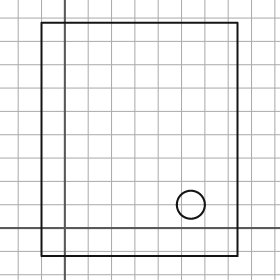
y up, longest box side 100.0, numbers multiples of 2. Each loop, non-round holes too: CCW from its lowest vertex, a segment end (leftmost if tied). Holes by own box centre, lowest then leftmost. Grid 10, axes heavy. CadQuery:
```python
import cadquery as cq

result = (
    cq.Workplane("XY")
    .moveTo(-10.0, -12.0)
    .lineTo(74.0, -12.0)
    .lineTo(74.0, 88.0)
    .lineTo(-10.0, 88.0)
    .close()
    .moveTo(54.0, 10.0)
    .circle(6.0)
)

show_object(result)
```